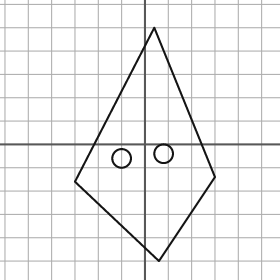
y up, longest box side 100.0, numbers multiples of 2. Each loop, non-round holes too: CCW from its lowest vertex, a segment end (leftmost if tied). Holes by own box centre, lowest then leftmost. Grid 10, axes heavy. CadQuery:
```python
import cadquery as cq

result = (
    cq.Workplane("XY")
    .moveTo(6.0, -50.0)
    .lineTo(30.0, -14.0)
    .lineTo(4.0, 50.0)
    .lineTo(-30.0, -16.0)
    .close()
    .moveTo(-10.0, -6.0)
    .circle(4.0)
    .moveTo(8.0, -4.0)
    .circle(4.0)
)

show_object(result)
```